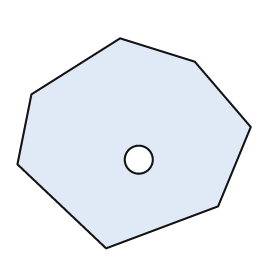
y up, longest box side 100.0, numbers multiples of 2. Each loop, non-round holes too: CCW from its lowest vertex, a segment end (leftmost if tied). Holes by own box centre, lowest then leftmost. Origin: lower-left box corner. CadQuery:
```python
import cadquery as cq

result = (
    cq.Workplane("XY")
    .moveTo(38.0, 0.0)
    .lineTo(86.0, 18.0)
    .lineTo(100.0, 52.0)
    .lineTo(76.0, 80.0)
    .lineTo(44.0, 90.0)
    .lineTo(6.0, 66.0)
    .lineTo(0.0, 36.0)
    .close()
    .moveTo(52.0, 38.0)
    .circle(6.0)
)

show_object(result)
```